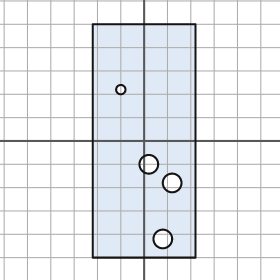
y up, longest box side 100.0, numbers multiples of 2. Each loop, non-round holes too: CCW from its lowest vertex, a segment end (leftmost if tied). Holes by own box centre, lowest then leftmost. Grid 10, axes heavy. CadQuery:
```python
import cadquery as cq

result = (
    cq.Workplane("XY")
    .moveTo(-22.0, -50.0)
    .lineTo(22.0, -50.0)
    .lineTo(22.0, 50.0)
    .lineTo(-22.0, 50.0)
    .close()
    .moveTo(8.0, -42.0)
    .circle(4.0)
    .moveTo(12.0, -18.0)
    .circle(4.0)
    .moveTo(2.0, -10.0)
    .circle(4.0)
    .moveTo(-10.0, 22.0)
    .circle(2.0)
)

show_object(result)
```